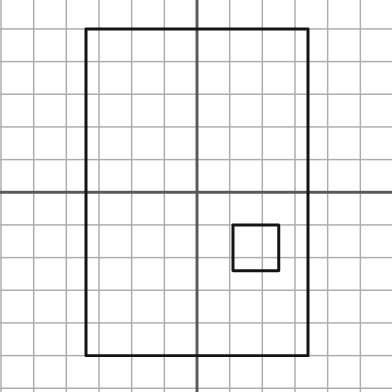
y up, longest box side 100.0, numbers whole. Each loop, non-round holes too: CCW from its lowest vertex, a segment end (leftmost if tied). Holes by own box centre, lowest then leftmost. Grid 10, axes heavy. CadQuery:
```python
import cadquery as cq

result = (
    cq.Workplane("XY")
    .moveTo(-34.0, -50.0)
    .lineTo(34.0, -50.0)
    .lineTo(34.0, 50.0)
    .lineTo(-34.0, 50.0)
    .close()
    .moveTo(11.0, -24.0)
    .lineTo(25.0, -24.0)
    .lineTo(25.0, -10.0)
    .lineTo(11.0, -10.0)
    .close()
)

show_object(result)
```